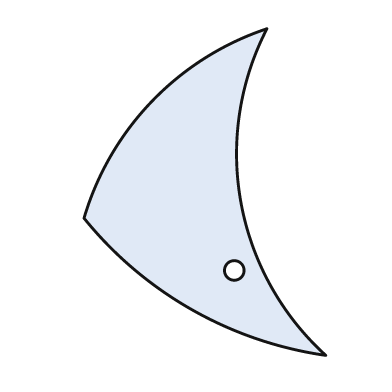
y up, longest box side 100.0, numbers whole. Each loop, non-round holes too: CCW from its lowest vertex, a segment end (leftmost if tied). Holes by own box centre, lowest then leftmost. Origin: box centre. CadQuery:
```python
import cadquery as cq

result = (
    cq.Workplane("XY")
    .moveTo(37.0, -50.0)
    .threePointArc((11.0, -3.0), (19.0, 50.0))
    .threePointArc((-16.0, 28.0), (-37.0, -8.0))
    .threePointArc((-4.0, -36.0), (37.0, -50.0))
    .close()
    .moveTo(9.0, -24.0)
    .circle(3.0)
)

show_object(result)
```